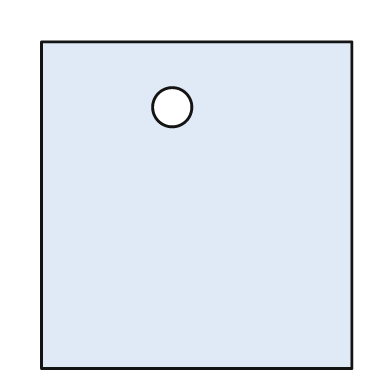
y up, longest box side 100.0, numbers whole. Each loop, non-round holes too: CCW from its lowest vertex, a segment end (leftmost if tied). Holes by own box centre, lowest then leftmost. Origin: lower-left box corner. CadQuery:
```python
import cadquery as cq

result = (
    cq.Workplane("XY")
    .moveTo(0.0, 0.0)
    .lineTo(95.0, 0.0)
    .lineTo(95.0, 100.0)
    .lineTo(0.0, 100.0)
    .close()
    .moveTo(40.0, 80.0)
    .circle(6.0)
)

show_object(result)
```